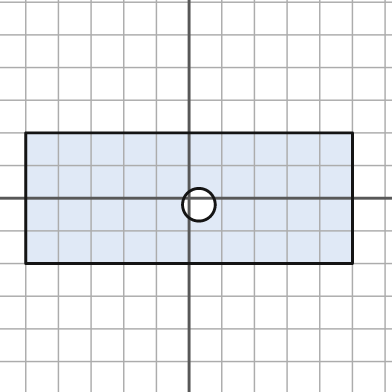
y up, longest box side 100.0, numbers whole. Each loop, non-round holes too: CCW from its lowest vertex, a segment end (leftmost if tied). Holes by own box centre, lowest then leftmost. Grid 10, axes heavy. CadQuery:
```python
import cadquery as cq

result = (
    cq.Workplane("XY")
    .moveTo(-50.0, -20.0)
    .lineTo(50.0, -20.0)
    .lineTo(50.0, 20.0)
    .lineTo(-50.0, 20.0)
    .close()
    .moveTo(3.0, -2.0)
    .circle(5.0)
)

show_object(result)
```